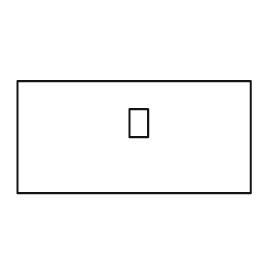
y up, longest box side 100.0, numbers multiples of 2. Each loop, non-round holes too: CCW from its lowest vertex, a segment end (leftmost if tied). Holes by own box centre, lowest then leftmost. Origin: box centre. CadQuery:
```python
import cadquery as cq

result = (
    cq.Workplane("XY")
    .moveTo(-50.0, -24.0)
    .lineTo(50.0, -24.0)
    .lineTo(50.0, 24.0)
    .lineTo(-50.0, 24.0)
    .close()
    .moveTo(-2.0, 0.0)
    .lineTo(6.0, 0.0)
    .lineTo(6.0, 12.0)
    .lineTo(-2.0, 12.0)
    .close()
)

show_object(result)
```